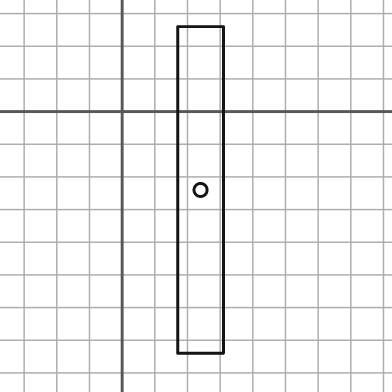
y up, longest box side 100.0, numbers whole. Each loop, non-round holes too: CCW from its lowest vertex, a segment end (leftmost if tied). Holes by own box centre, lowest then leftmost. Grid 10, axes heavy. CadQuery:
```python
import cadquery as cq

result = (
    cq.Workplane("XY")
    .moveTo(17.0, -74.0)
    .lineTo(31.0, -74.0)
    .lineTo(31.0, 26.0)
    .lineTo(17.0, 26.0)
    .close()
    .moveTo(24.0, -24.0)
    .circle(2.0)
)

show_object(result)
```